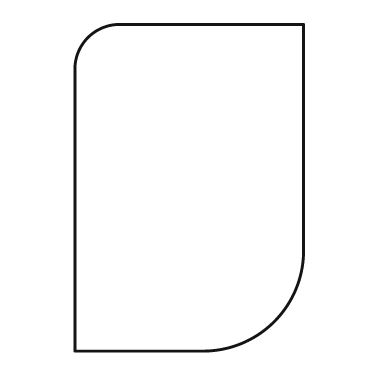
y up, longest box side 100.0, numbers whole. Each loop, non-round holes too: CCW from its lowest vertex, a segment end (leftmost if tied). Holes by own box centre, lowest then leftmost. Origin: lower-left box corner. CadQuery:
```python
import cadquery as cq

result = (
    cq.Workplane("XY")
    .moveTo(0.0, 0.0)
    .lineTo(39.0, 0.0)
    .threePointArc((61.0, 9.0), (70.0, 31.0))
    .lineTo(70.0, 100.0)
    .lineTo(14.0, 100.0)
    .threePointArc((4.0, 96.0), (0.0, 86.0))
    .close()
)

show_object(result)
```